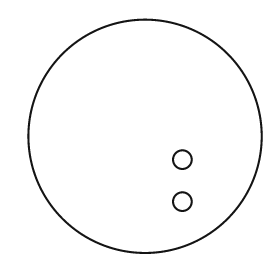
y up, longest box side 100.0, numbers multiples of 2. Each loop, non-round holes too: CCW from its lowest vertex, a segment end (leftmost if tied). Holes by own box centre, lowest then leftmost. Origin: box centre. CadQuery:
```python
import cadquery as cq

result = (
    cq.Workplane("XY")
    .moveTo(0.0, 0.0)
    .circle(50.0)
    .moveTo(16.0, -28.0)
    .circle(4.0)
    .moveTo(16.0, -10.0)
    .circle(4.0)
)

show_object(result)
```